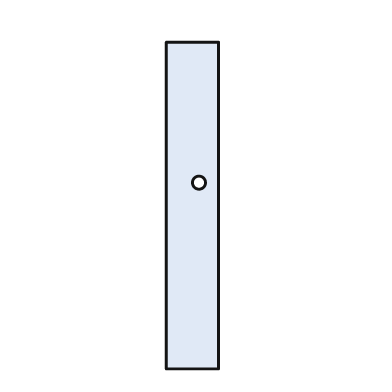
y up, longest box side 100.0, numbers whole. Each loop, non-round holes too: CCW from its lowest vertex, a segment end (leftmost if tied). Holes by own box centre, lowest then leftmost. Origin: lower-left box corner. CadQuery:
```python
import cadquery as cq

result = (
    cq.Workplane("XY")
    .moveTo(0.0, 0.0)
    .lineTo(16.0, 0.0)
    .lineTo(16.0, 100.0)
    .lineTo(0.0, 100.0)
    .close()
    .moveTo(10.0, 57.0)
    .circle(2.0)
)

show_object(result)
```